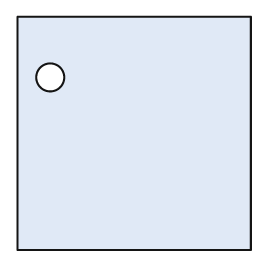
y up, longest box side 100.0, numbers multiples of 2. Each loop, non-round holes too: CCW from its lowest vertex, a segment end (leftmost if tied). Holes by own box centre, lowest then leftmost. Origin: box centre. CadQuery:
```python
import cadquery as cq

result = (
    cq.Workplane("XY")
    .moveTo(-50.0, -50.0)
    .lineTo(50.0, -50.0)
    .lineTo(50.0, 50.0)
    .lineTo(-50.0, 50.0)
    .close()
    .moveTo(-36.0, 24.0)
    .circle(6.0)
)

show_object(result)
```